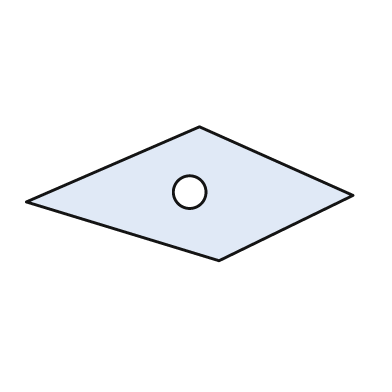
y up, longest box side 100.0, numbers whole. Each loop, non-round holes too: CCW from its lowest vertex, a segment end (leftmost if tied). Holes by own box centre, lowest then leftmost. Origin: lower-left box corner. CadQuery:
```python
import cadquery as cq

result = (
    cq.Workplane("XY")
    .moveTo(59.0, 0.0)
    .lineTo(100.0, 20.0)
    .lineTo(53.0, 41.0)
    .lineTo(0.0, 18.0)
    .close()
    .moveTo(50.0, 21.0)
    .circle(5.0)
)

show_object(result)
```